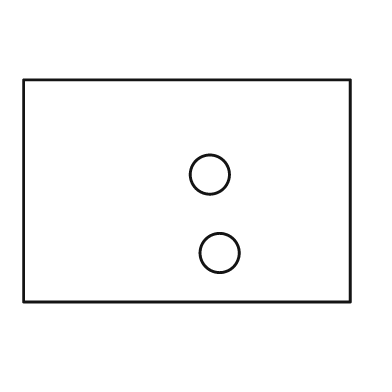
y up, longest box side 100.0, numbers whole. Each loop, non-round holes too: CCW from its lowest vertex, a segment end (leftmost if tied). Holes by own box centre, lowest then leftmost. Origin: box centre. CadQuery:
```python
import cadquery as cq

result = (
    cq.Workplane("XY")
    .moveTo(-50.0, -34.0)
    .lineTo(50.0, -34.0)
    .lineTo(50.0, 34.0)
    .lineTo(-50.0, 34.0)
    .close()
    .moveTo(10.0, -19.0)
    .circle(6.0)
    .moveTo(7.0, 5.0)
    .circle(6.0)
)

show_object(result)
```